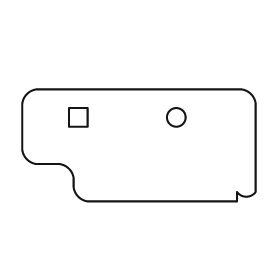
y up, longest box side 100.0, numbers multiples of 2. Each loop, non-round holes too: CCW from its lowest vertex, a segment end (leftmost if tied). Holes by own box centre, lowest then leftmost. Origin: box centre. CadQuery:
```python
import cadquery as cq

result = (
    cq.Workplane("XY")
    .moveTo(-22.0, -24.0)
    .lineTo(42.0, -24.0)
    .lineTo(42.0, -20.0)
    .threePointArc((46.0, -22.0), (50.0, -20.0))
    .lineTo(50.0, 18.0)
    .threePointArc((48.0, 22.0), (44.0, 24.0))
    .lineTo(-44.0, 24.0)
    .threePointArc((-48.0, 22.0), (-50.0, 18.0))
    .lineTo(-50.0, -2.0)
    .threePointArc((-48.0, -6.0), (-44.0, -8.0))
    .lineTo(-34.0, -8.0)
    .threePointArc((-30.0, -10.0), (-28.0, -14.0))
    .lineTo(-28.0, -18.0)
    .threePointArc((-26.0, -22.0), (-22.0, -24.0))
    .close()
    .moveTo(-30.0, 8.0)
    .lineTo(-22.0, 8.0)
    .lineTo(-22.0, 16.0)
    .lineTo(-30.0, 16.0)
    .close()
    .moveTo(16.0, 12.0)
    .circle(4.0)
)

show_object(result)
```